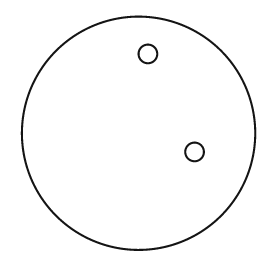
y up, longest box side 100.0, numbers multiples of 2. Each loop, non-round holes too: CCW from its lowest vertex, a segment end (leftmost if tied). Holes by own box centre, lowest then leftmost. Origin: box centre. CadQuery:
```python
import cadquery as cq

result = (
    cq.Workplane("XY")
    .moveTo(0.0, 0.0)
    .circle(50.0)
    .moveTo(24.0, -8.0)
    .circle(4.0)
    .moveTo(4.0, 34.0)
    .circle(4.0)
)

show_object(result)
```